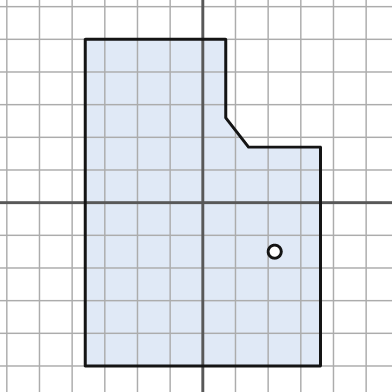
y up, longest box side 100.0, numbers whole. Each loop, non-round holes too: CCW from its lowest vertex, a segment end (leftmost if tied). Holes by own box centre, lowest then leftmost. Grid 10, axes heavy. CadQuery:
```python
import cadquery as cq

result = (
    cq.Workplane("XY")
    .moveTo(-36.0, -50.0)
    .lineTo(36.0, -50.0)
    .lineTo(36.0, 17.0)
    .lineTo(14.0, 17.0)
    .lineTo(7.0, 26.0)
    .lineTo(7.0, 50.0)
    .lineTo(-36.0, 50.0)
    .close()
    .moveTo(22.0, -15.0)
    .circle(2.0)
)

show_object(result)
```